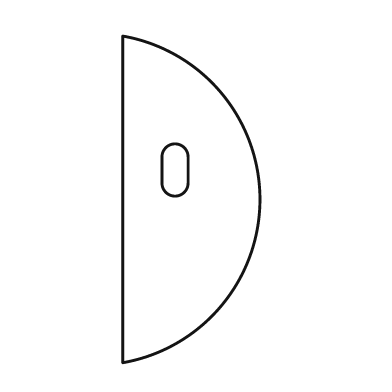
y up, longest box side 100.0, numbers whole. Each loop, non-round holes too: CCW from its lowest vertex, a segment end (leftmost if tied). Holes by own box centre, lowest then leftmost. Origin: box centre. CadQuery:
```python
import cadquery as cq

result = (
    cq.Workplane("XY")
    .moveTo(-21.0, -50.0)
    .threePointArc((21.0, 0.0), (-21.0, 50.0))
    .close()
    .moveTo(-9.0, 5.0)
    .threePointArc((-5.0, 1.0), (-1.0, 5.0))
    .lineTo(-1.0, 13.0)
    .threePointArc((-5.0, 17.0), (-9.0, 13.0))
    .close()
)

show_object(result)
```